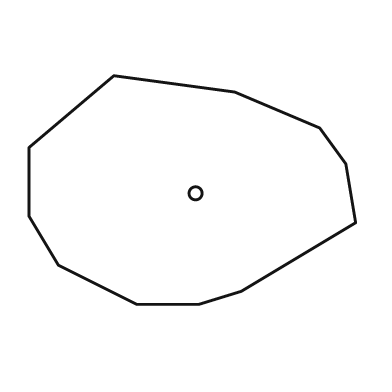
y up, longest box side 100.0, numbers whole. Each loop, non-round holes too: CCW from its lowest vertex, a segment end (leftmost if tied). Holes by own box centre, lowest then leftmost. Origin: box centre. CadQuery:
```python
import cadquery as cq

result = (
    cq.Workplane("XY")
    .moveTo(-17.0, -35.0)
    .lineTo(2.0, -35.0)
    .lineTo(15.0, -31.0)
    .lineTo(50.0, -10.0)
    .lineTo(47.0, 8.0)
    .lineTo(39.0, 19.0)
    .lineTo(13.0, 30.0)
    .lineTo(-24.0, 35.0)
    .lineTo(-50.0, 13.0)
    .lineTo(-50.0, -8.0)
    .lineTo(-41.0, -23.0)
    .close()
    .moveTo(1.0, -1.0)
    .circle(2.0)
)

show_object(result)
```